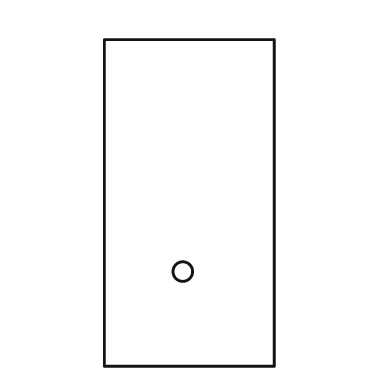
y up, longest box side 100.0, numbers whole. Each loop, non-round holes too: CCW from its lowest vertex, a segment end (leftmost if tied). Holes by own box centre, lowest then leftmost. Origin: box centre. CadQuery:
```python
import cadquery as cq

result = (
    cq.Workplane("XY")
    .moveTo(-26.0, -50.0)
    .lineTo(26.0, -50.0)
    .lineTo(26.0, 50.0)
    .lineTo(-26.0, 50.0)
    .close()
    .moveTo(-2.0, -21.0)
    .circle(3.0)
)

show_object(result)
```